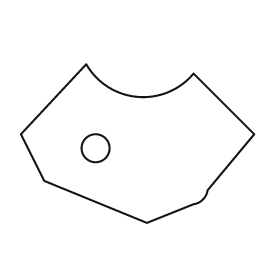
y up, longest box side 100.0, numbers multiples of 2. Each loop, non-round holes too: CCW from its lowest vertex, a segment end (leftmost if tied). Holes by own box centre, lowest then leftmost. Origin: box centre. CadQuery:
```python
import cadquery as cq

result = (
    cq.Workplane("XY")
    .moveTo(4.0, -34.0)
    .lineTo(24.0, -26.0)
    .threePointArc((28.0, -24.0), (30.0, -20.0))
    .lineTo(50.0, 4.0)
    .lineTo(24.0, 30.0)
    .threePointArc((0.0, 20.0), (-22.0, 34.0))
    .lineTo(-50.0, 4.0)
    .lineTo(-40.0, -16.0)
    .close()
    .moveTo(-18.0, -2.0)
    .circle(6.0)
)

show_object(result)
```